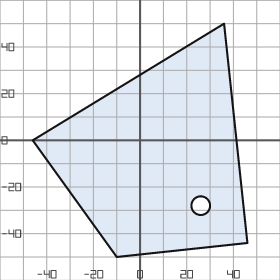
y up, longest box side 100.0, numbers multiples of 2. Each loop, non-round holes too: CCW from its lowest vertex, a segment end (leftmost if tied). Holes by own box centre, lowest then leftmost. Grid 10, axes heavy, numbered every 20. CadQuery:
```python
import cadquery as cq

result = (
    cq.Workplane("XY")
    .moveTo(-10.0, -50.0)
    .lineTo(46.0, -44.0)
    .lineTo(36.0, 50.0)
    .lineTo(-46.0, 0.0)
    .close()
    .moveTo(26.0, -28.0)
    .circle(4.0)
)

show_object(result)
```